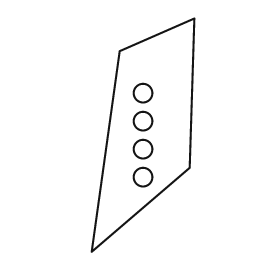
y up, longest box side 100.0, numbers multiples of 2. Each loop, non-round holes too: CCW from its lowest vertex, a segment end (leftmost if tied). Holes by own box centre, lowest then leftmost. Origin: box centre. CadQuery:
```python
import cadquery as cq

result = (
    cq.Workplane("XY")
    .moveTo(-22.0, -50.0)
    .lineTo(20.0, -14.0)
    .lineTo(22.0, 50.0)
    .lineTo(-10.0, 36.0)
    .close()
    .moveTo(0.0, -18.0)
    .circle(4.0)
    .moveTo(0.0, -6.0)
    .circle(4.0)
    .moveTo(0.0, 6.0)
    .circle(4.0)
    .moveTo(0.0, 18.0)
    .circle(4.0)
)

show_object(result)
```